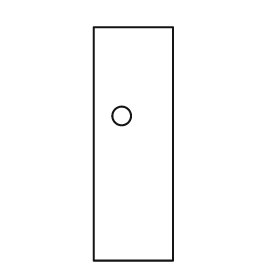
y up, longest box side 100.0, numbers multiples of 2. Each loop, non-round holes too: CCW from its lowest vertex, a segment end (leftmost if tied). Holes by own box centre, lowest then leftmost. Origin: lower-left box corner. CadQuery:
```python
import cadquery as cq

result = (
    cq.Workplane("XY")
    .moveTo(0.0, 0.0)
    .lineTo(34.0, 0.0)
    .lineTo(34.0, 100.0)
    .lineTo(0.0, 100.0)
    .close()
    .moveTo(12.0, 62.0)
    .circle(4.0)
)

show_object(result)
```